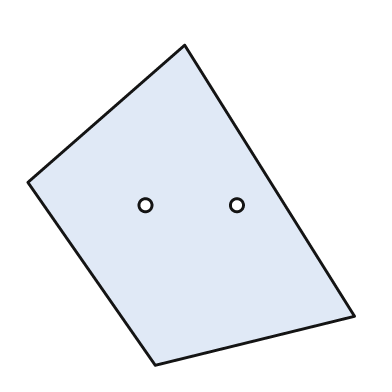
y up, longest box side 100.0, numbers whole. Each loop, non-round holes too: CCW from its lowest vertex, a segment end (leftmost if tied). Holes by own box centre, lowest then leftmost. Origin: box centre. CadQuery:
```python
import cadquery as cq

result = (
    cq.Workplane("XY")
    .moveTo(-11.0, -49.0)
    .lineTo(50.0, -34.0)
    .lineTo(-2.0, 49.0)
    .lineTo(-50.0, 7.0)
    .close()
    .moveTo(-14.0, 0.0)
    .circle(2.0)
    .moveTo(14.0, 0.0)
    .circle(2.0)
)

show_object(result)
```